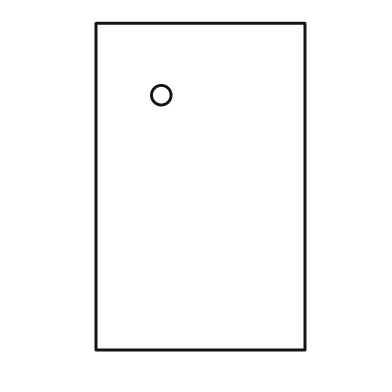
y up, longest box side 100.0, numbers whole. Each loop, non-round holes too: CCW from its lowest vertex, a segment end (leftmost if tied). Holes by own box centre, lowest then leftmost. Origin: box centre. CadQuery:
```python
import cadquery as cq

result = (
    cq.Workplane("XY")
    .moveTo(-32.0, -50.0)
    .lineTo(32.0, -50.0)
    .lineTo(32.0, 50.0)
    .lineTo(-32.0, 50.0)
    .close()
    .moveTo(-12.0, 28.0)
    .circle(3.0)
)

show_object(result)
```